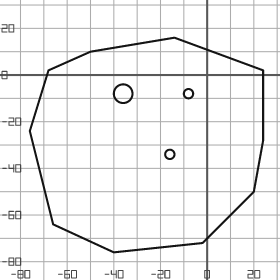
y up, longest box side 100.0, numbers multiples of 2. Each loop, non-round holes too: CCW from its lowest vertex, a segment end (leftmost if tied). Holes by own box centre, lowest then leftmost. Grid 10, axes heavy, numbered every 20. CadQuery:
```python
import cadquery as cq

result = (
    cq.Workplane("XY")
    .moveTo(-40.0, -76.0)
    .lineTo(-2.0, -72.0)
    .lineTo(20.0, -50.0)
    .lineTo(24.0, -28.0)
    .lineTo(24.0, 2.0)
    .lineTo(-14.0, 16.0)
    .lineTo(-50.0, 10.0)
    .lineTo(-68.0, 2.0)
    .lineTo(-76.0, -24.0)
    .lineTo(-66.0, -64.0)
    .close()
    .moveTo(-16.0, -34.0)
    .circle(2.0)
    .moveTo(-36.0, -8.0)
    .circle(4.0)
    .moveTo(-8.0, -8.0)
    .circle(2.0)
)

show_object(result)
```